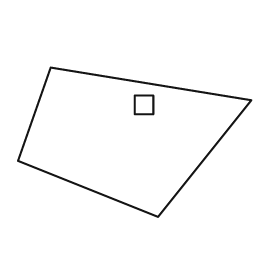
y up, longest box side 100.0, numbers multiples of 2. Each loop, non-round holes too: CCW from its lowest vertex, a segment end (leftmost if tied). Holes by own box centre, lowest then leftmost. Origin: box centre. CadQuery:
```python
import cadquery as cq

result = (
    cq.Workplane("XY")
    .moveTo(10.0, -32.0)
    .lineTo(50.0, 18.0)
    .lineTo(-36.0, 32.0)
    .lineTo(-50.0, -8.0)
    .close()
    .moveTo(0.0, 12.0)
    .lineTo(8.0, 12.0)
    .lineTo(8.0, 20.0)
    .lineTo(0.0, 20.0)
    .close()
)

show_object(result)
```